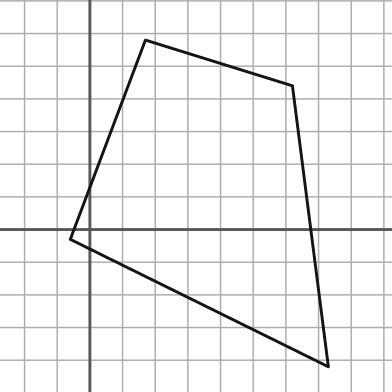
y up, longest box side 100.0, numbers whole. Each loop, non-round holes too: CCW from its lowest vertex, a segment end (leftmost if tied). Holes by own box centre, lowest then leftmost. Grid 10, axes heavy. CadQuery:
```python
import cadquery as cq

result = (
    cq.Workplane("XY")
    .moveTo(73.0, -42.0)
    .lineTo(62.0, 44.0)
    .lineTo(17.0, 58.0)
    .lineTo(-6.0, -3.0)
    .close()
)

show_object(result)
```